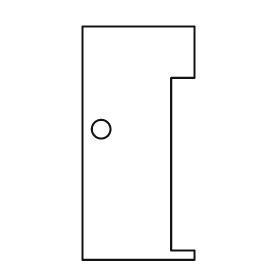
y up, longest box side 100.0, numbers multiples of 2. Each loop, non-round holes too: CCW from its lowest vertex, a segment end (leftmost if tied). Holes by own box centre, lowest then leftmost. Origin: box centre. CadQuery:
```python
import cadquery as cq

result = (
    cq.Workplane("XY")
    .moveTo(-24.0, -50.0)
    .lineTo(24.0, -50.0)
    .lineTo(24.0, -46.0)
    .lineTo(14.0, -46.0)
    .lineTo(14.0, 28.0)
    .lineTo(24.0, 28.0)
    .lineTo(24.0, 50.0)
    .lineTo(-24.0, 50.0)
    .close()
    .moveTo(-16.0, 6.0)
    .circle(4.0)
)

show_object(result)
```